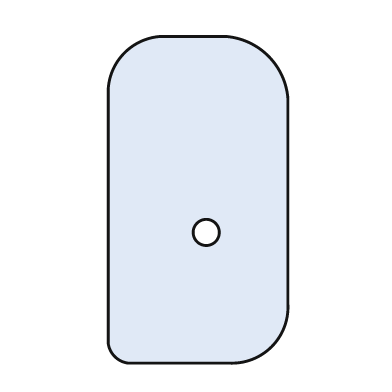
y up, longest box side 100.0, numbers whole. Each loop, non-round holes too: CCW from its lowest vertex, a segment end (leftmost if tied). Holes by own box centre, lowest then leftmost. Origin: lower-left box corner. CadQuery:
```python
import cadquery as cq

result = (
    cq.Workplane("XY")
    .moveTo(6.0, 0.0)
    .lineTo(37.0, 0.0)
    .threePointArc((50.0, 5.0), (55.0, 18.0))
    .lineTo(55.0, 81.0)
    .threePointArc((49.0, 94.0), (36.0, 100.0))
    .lineTo(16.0, 100.0)
    .threePointArc((5.0, 95.0), (0.0, 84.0))
    .lineTo(0.0, 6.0)
    .threePointArc((2.0, 2.0), (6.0, 0.0))
    .close()
    .moveTo(30.0, 40.0)
    .circle(4.0)
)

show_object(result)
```